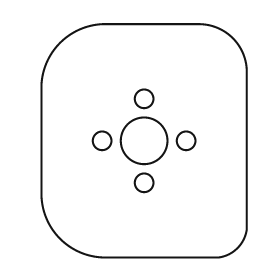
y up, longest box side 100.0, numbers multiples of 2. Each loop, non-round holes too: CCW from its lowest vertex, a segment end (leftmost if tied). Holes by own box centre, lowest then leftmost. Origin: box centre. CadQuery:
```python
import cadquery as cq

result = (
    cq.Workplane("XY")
    .moveTo(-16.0, -50.0)
    .lineTo(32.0, -50.0)
    .threePointArc((40.0, -46.0), (44.0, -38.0))
    .lineTo(44.0, 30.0)
    .threePointArc((38.0, 44.0), (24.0, 50.0))
    .lineTo(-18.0, 50.0)
    .threePointArc((-36.0, 42.0), (-44.0, 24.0))
    .lineTo(-44.0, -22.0)
    .threePointArc((-36.0, -42.0), (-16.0, -50.0))
    .close()
    .moveTo(0.0, -18.0)
    .circle(4.0)
    .moveTo(-18.0, 0.0)
    .circle(4.0)
    .moveTo(0.0, 0.0)
    .circle(10.0)
    .moveTo(18.0, 0.0)
    .circle(4.0)
    .moveTo(0.0, 18.0)
    .circle(4.0)
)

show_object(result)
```